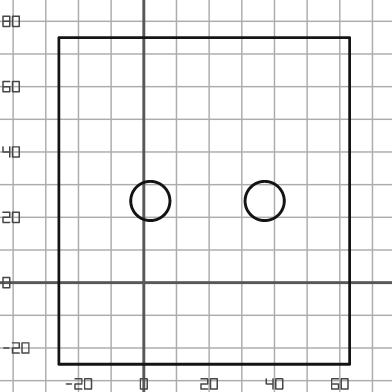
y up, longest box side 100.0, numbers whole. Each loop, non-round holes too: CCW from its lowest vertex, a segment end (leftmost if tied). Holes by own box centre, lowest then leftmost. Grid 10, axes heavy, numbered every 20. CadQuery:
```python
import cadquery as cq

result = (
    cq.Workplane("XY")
    .moveTo(-26.0, -25.0)
    .lineTo(63.0, -25.0)
    .lineTo(63.0, 75.0)
    .lineTo(-26.0, 75.0)
    .close()
    .moveTo(2.0, 25.0)
    .circle(6.0)
    .moveTo(37.0, 25.0)
    .circle(6.0)
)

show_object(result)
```